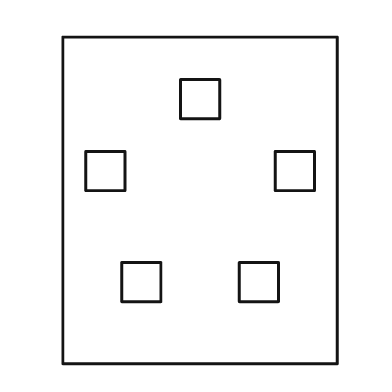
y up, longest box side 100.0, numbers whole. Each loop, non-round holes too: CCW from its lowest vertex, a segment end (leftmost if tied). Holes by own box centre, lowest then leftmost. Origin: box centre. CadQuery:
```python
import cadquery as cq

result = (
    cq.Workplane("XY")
    .moveTo(-42.0, -50.0)
    .lineTo(42.0, -50.0)
    .lineTo(42.0, 50.0)
    .lineTo(-42.0, 50.0)
    .close()
    .moveTo(-24.0, -31.0)
    .lineTo(-12.0, -31.0)
    .lineTo(-12.0, -19.0)
    .lineTo(-24.0, -19.0)
    .close()
    .moveTo(12.0, -31.0)
    .lineTo(24.0, -31.0)
    .lineTo(24.0, -19.0)
    .lineTo(12.0, -19.0)
    .close()
    .moveTo(-35.0, 3.0)
    .lineTo(-23.0, 3.0)
    .lineTo(-23.0, 15.0)
    .lineTo(-35.0, 15.0)
    .close()
    .moveTo(23.0, 3.0)
    .lineTo(35.0, 3.0)
    .lineTo(35.0, 15.0)
    .lineTo(23.0, 15.0)
    .close()
    .moveTo(-6.0, 25.0)
    .lineTo(6.0, 25.0)
    .lineTo(6.0, 37.0)
    .lineTo(-6.0, 37.0)
    .close()
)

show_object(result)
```